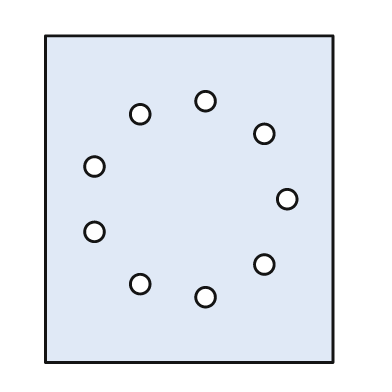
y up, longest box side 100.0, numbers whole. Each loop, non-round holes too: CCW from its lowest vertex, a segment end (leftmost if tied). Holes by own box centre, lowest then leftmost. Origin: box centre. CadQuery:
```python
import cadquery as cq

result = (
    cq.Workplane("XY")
    .moveTo(-44.0, -50.0)
    .lineTo(44.0, -50.0)
    .lineTo(44.0, 50.0)
    .lineTo(-44.0, 50.0)
    .close()
    .moveTo(5.0, -30.0)
    .circle(3.0)
    .moveTo(-15.0, -26.0)
    .circle(3.0)
    .moveTo(23.0, -20.0)
    .circle(3.0)
    .moveTo(-29.0, -10.0)
    .circle(3.0)
    .moveTo(30.0, 0.0)
    .circle(3.0)
    .moveTo(-29.0, 10.0)
    .circle(3.0)
    .moveTo(23.0, 20.0)
    .circle(3.0)
    .moveTo(-15.0, 26.0)
    .circle(3.0)
    .moveTo(5.0, 30.0)
    .circle(3.0)
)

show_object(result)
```